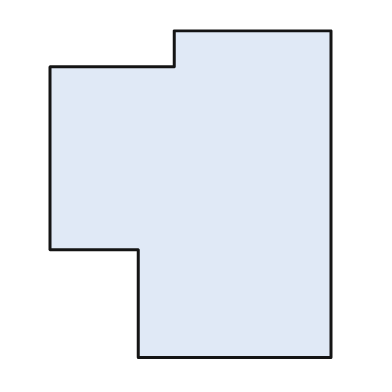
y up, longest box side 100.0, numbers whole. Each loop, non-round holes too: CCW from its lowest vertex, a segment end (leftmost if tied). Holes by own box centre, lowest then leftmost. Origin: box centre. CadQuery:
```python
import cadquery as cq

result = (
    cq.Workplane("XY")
    .moveTo(-16.0, -50.0)
    .lineTo(43.0, -50.0)
    .lineTo(43.0, 50.0)
    .lineTo(-5.0, 50.0)
    .lineTo(-5.0, 39.0)
    .lineTo(-43.0, 39.0)
    .lineTo(-43.0, -17.0)
    .lineTo(-16.0, -17.0)
    .close()
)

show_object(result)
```